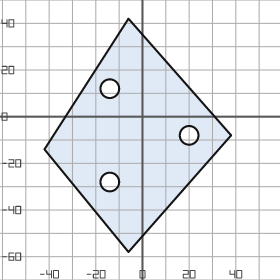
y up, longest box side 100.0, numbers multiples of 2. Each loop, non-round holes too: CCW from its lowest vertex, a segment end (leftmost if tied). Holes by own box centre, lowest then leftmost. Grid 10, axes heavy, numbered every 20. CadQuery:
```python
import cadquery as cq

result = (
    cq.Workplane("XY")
    .moveTo(-6.0, -58.0)
    .lineTo(38.0, -8.0)
    .lineTo(-6.0, 42.0)
    .lineTo(-42.0, -14.0)
    .close()
    .moveTo(-14.0, -28.0)
    .circle(4.0)
    .moveTo(20.0, -8.0)
    .circle(4.0)
    .moveTo(-14.0, 12.0)
    .circle(4.0)
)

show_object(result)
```